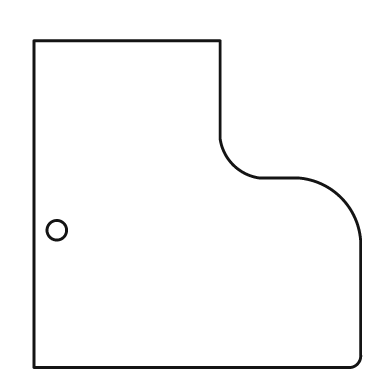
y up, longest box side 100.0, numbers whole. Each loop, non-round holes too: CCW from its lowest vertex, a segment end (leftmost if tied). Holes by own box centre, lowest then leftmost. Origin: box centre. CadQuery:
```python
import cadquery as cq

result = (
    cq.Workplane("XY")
    .moveTo(-50.0, -50.0)
    .lineTo(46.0, -50.0)
    .threePointArc((49.0, -49.0), (50.0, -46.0))
    .lineTo(50.0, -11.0)
    .threePointArc((44.0, 2.0), (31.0, 8.0))
    .lineTo(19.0, 8.0)
    .threePointArc((11.0, 12.0), (7.0, 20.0))
    .lineTo(7.0, 50.0)
    .lineTo(-50.0, 50.0)
    .close()
    .moveTo(-43.0, -8.0)
    .circle(3.0)
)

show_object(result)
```